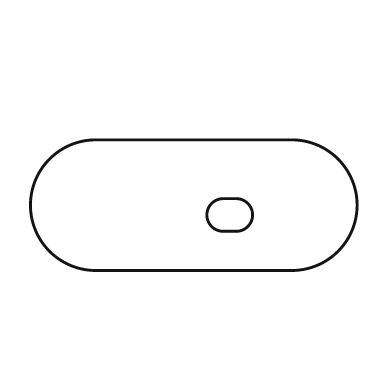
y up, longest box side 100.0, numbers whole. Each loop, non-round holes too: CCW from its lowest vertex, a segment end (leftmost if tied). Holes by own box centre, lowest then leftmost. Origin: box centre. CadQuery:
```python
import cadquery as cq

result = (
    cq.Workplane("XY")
    .moveTo(-30.0, -20.0)
    .lineTo(30.0, -20.0)
    .threePointArc((50.0, 0.0), (30.0, 20.0))
    .lineTo(-30.0, 20.0)
    .threePointArc((-50.0, 0.0), (-30.0, -20.0))
    .close()
    .moveTo(9.0, -8.0)
    .lineTo(13.0, -8.0)
    .threePointArc((18.0, -3.0), (13.0, 2.0))
    .lineTo(9.0, 2.0)
    .threePointArc((4.0, -3.0), (9.0, -8.0))
    .close()
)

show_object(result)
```